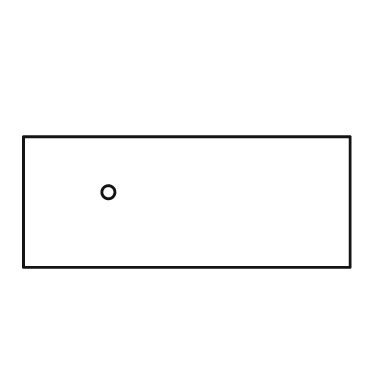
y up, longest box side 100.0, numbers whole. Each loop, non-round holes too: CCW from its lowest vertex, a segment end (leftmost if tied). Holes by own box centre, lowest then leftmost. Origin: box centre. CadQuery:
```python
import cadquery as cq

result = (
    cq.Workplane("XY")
    .moveTo(-50.0, -20.0)
    .lineTo(50.0, -20.0)
    .lineTo(50.0, 20.0)
    .lineTo(-50.0, 20.0)
    .close()
    .moveTo(-24.0, 3.0)
    .circle(2.0)
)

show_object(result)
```